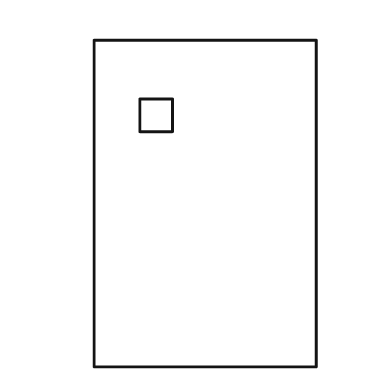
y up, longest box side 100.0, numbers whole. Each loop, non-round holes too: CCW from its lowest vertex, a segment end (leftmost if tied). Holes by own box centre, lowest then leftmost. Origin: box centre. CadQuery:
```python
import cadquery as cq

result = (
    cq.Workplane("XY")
    .moveTo(-34.0, -50.0)
    .lineTo(34.0, -50.0)
    .lineTo(34.0, 50.0)
    .lineTo(-34.0, 50.0)
    .close()
    .moveTo(-20.0, 22.0)
    .lineTo(-10.0, 22.0)
    .lineTo(-10.0, 32.0)
    .lineTo(-20.0, 32.0)
    .close()
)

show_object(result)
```